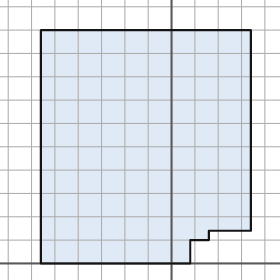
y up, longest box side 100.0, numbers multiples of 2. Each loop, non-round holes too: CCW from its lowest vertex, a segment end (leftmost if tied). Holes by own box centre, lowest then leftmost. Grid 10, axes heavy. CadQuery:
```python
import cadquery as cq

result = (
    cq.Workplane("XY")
    .moveTo(-56.0, 0.0)
    .lineTo(8.0, 0.0)
    .lineTo(8.0, 10.0)
    .lineTo(16.0, 10.0)
    .lineTo(16.0, 14.0)
    .lineTo(34.0, 14.0)
    .lineTo(34.0, 100.0)
    .lineTo(-56.0, 100.0)
    .close()
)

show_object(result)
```